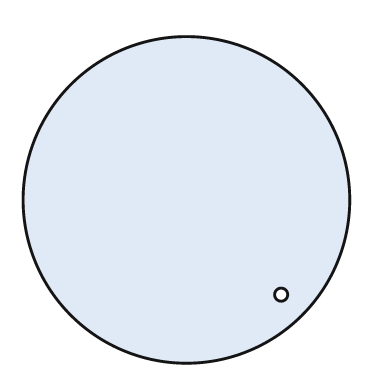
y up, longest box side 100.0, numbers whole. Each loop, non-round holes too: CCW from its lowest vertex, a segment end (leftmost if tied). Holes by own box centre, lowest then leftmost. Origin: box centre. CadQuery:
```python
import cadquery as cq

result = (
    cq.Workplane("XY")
    .moveTo(0.0, 0.0)
    .circle(50.0)
    .moveTo(29.0, -29.0)
    .circle(2.0)
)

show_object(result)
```